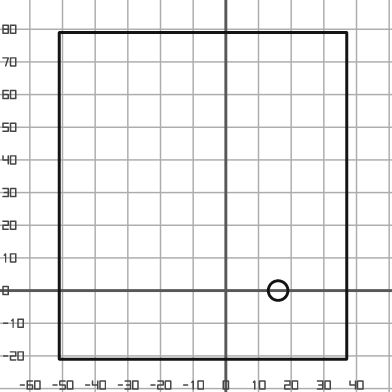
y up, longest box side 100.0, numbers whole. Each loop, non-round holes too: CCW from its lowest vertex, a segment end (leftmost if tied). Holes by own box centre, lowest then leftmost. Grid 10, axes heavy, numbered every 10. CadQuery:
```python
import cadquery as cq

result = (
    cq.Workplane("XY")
    .moveTo(-51.0, -21.0)
    .lineTo(37.0, -21.0)
    .lineTo(37.0, 79.0)
    .lineTo(-51.0, 79.0)
    .close()
    .moveTo(16.0, 0.0)
    .circle(3.0)
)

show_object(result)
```